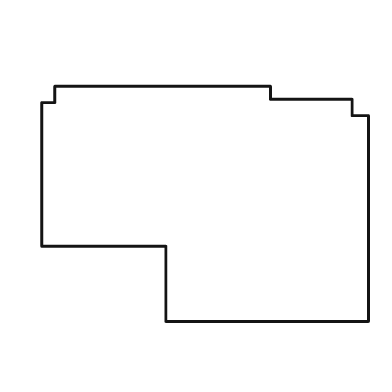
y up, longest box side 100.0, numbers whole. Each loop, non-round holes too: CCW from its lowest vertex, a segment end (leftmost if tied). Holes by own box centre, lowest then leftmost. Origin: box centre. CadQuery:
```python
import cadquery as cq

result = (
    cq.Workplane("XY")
    .moveTo(-12.0, -36.0)
    .lineTo(50.0, -36.0)
    .lineTo(50.0, 27.0)
    .lineTo(45.0, 27.0)
    .lineTo(45.0, 32.0)
    .lineTo(20.0, 32.0)
    .lineTo(20.0, 36.0)
    .lineTo(-46.0, 36.0)
    .lineTo(-46.0, 31.0)
    .lineTo(-50.0, 31.0)
    .lineTo(-50.0, -13.0)
    .lineTo(-12.0, -13.0)
    .close()
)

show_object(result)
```